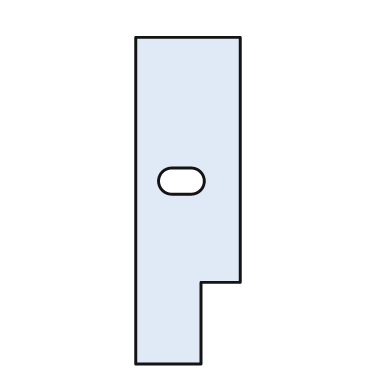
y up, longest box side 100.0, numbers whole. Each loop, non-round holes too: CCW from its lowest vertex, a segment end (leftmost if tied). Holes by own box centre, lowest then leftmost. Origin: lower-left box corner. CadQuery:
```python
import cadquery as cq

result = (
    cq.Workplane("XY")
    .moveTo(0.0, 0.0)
    .lineTo(20.0, 0.0)
    .lineTo(20.0, 25.0)
    .lineTo(32.0, 25.0)
    .lineTo(32.0, 100.0)
    .lineTo(0.0, 100.0)
    .close()
    .moveTo(11.0, 52.0)
    .lineTo(17.0, 52.0)
    .threePointArc((21.0, 56.0), (17.0, 60.0))
    .lineTo(11.0, 60.0)
    .threePointArc((7.0, 56.0), (11.0, 52.0))
    .close()
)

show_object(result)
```